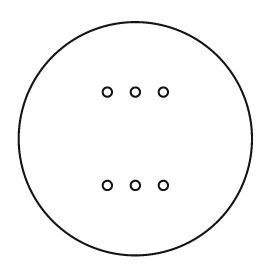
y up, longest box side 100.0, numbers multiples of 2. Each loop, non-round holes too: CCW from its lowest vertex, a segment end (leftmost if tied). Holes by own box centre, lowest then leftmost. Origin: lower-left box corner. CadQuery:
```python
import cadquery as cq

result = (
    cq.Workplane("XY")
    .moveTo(50.0, 50.0)
    .circle(50.0)
    .moveTo(38.0, 30.0)
    .circle(2.0)
    .moveTo(50.0, 30.0)
    .circle(2.0)
    .moveTo(62.0, 30.0)
    .circle(2.0)
    .moveTo(38.0, 70.0)
    .circle(2.0)
    .moveTo(50.0, 70.0)
    .circle(2.0)
    .moveTo(62.0, 70.0)
    .circle(2.0)
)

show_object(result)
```